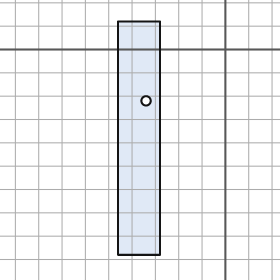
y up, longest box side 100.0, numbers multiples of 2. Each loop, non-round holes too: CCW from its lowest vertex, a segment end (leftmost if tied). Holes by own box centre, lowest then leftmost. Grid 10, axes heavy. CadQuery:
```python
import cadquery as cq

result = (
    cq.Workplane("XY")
    .moveTo(-46.0, -88.0)
    .lineTo(-28.0, -88.0)
    .lineTo(-28.0, 12.0)
    .lineTo(-46.0, 12.0)
    .close()
    .moveTo(-34.0, -22.0)
    .circle(2.0)
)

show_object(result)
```